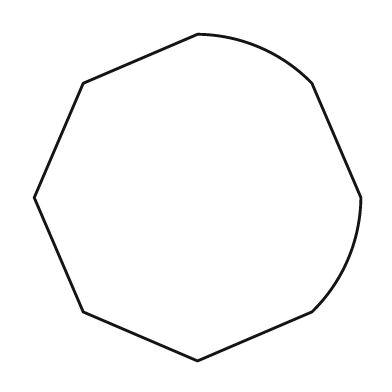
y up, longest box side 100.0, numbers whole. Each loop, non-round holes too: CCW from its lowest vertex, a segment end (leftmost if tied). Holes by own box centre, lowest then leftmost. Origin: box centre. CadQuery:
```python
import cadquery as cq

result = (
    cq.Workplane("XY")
    .moveTo(0.0, -50.0)
    .lineTo(35.0, -35.0)
    .threePointArc((46.0, -19.0), (50.0, 0.0))
    .lineTo(35.0, 35.0)
    .threePointArc((19.0, 46.0), (0.0, 50.0))
    .lineTo(-35.0, 35.0)
    .lineTo(-50.0, 0.0)
    .lineTo(-35.0, -35.0)
    .close()
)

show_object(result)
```